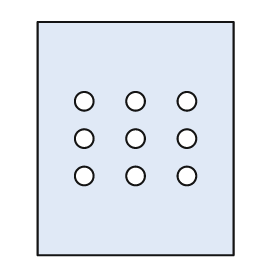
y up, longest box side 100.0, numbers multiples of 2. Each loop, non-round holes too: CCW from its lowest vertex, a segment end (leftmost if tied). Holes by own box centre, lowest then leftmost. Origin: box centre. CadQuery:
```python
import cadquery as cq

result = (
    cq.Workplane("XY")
    .moveTo(-42.0, -50.0)
    .lineTo(42.0, -50.0)
    .lineTo(42.0, 50.0)
    .lineTo(-42.0, 50.0)
    .close()
    .moveTo(-22.0, -16.0)
    .circle(4.0)
    .moveTo(0.0, -16.0)
    .circle(4.0)
    .moveTo(22.0, -16.0)
    .circle(4.0)
    .moveTo(-22.0, 0.0)
    .circle(4.0)
    .moveTo(0.0, 0.0)
    .circle(4.0)
    .moveTo(22.0, 0.0)
    .circle(4.0)
    .moveTo(-22.0, 16.0)
    .circle(4.0)
    .moveTo(0.0, 16.0)
    .circle(4.0)
    .moveTo(22.0, 16.0)
    .circle(4.0)
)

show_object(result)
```